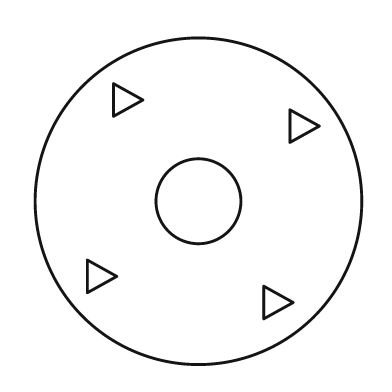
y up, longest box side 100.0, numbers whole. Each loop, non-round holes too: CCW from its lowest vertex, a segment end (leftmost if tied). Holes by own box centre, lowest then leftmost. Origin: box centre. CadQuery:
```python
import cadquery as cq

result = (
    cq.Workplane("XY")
    .moveTo(0.0, 0.0)
    .circle(50.0)
    .moveTo(20.0, -36.0)
    .lineTo(29.0, -31.0)
    .lineTo(20.0, -26.0)
    .close()
    .moveTo(-34.0, -28.0)
    .lineTo(-25.0, -23.0)
    .lineTo(-34.0, -18.0)
    .close()
    .moveTo(0.0, 0.0)
    .circle(13.0)
    .moveTo(28.0, 18.0)
    .lineTo(37.0, 23.0)
    .lineTo(28.0, 28.0)
    .close()
    .moveTo(-26.0, 26.0)
    .lineTo(-17.0, 31.0)
    .lineTo(-26.0, 36.0)
    .close()
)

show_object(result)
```